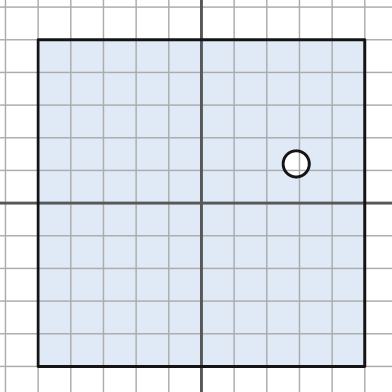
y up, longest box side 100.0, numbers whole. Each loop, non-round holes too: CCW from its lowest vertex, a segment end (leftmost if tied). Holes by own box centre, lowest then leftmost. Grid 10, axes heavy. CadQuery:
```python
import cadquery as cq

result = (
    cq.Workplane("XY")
    .moveTo(-50.0, -50.0)
    .lineTo(50.0, -50.0)
    .lineTo(50.0, 50.0)
    .lineTo(-50.0, 50.0)
    .close()
    .moveTo(29.0, 12.0)
    .circle(4.0)
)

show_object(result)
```